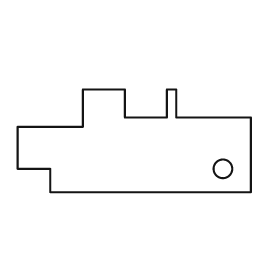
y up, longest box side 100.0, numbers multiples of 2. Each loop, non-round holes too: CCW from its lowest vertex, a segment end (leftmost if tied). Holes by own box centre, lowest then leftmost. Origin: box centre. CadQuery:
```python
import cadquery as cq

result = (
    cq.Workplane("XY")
    .moveTo(-36.0, -22.0)
    .lineTo(50.0, -22.0)
    .lineTo(50.0, 10.0)
    .lineTo(18.0, 10.0)
    .lineTo(18.0, 22.0)
    .lineTo(14.0, 22.0)
    .lineTo(14.0, 10.0)
    .lineTo(-4.0, 10.0)
    .lineTo(-4.0, 22.0)
    .lineTo(-22.0, 22.0)
    .lineTo(-22.0, 6.0)
    .lineTo(-50.0, 6.0)
    .lineTo(-50.0, -12.0)
    .lineTo(-36.0, -12.0)
    .close()
    .moveTo(38.0, -12.0)
    .circle(4.0)
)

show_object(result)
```